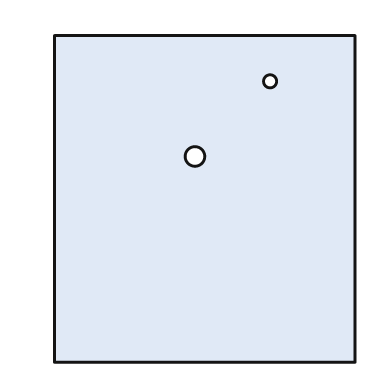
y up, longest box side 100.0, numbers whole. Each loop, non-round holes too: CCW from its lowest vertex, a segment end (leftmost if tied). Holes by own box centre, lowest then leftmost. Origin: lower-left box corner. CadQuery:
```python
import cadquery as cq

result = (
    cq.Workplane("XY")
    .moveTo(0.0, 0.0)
    .lineTo(92.0, 0.0)
    .lineTo(92.0, 100.0)
    .lineTo(0.0, 100.0)
    .close()
    .moveTo(43.0, 63.0)
    .circle(3.0)
    .moveTo(66.0, 86.0)
    .circle(2.0)
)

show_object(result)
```